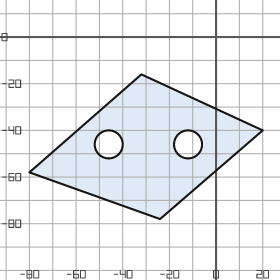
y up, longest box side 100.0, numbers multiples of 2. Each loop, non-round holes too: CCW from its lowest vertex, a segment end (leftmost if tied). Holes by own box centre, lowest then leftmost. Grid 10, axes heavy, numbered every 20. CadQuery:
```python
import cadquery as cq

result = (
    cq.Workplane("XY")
    .moveTo(-24.0, -78.0)
    .lineTo(20.0, -40.0)
    .lineTo(-32.0, -16.0)
    .lineTo(-80.0, -58.0)
    .close()
    .moveTo(-46.0, -46.0)
    .circle(6.0)
    .moveTo(-12.0, -46.0)
    .circle(6.0)
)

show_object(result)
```